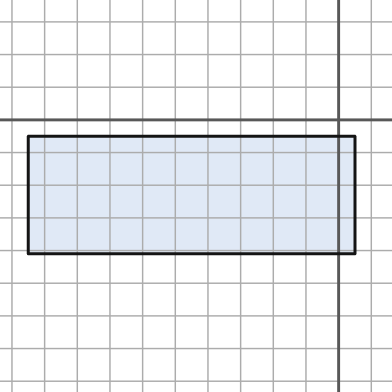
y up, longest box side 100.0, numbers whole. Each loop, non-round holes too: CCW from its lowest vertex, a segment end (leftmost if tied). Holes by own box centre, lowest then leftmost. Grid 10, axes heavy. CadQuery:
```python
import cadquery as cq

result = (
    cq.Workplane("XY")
    .moveTo(-95.0, -41.0)
    .lineTo(5.0, -41.0)
    .lineTo(5.0, -5.0)
    .lineTo(-95.0, -5.0)
    .close()
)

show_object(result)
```